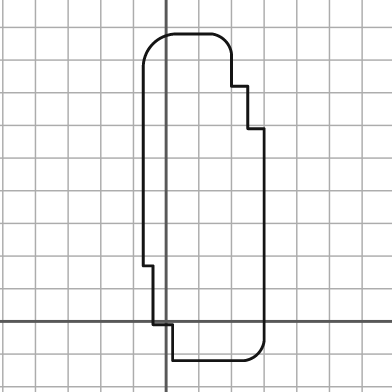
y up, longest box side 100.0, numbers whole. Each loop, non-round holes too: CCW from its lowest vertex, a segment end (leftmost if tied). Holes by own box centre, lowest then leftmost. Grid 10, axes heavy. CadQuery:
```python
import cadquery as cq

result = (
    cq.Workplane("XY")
    .moveTo(2.0, -12.0)
    .lineTo(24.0, -12.0)
    .threePointArc((28.0, -10.0), (30.0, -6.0))
    .lineTo(30.0, 59.0)
    .lineTo(25.0, 59.0)
    .lineTo(25.0, 72.0)
    .lineTo(20.0, 72.0)
    .lineTo(20.0, 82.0)
    .threePointArc((18.0, 86.0), (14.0, 88.0))
    .lineTo(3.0, 88.0)
    .threePointArc((-4.0, 85.0), (-7.0, 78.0))
    .lineTo(-7.0, 17.0)
    .lineTo(-4.0, 17.0)
    .lineTo(-4.0, -1.0)
    .lineTo(2.0, -1.0)
    .close()
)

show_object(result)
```